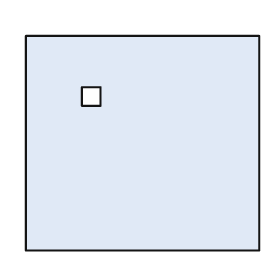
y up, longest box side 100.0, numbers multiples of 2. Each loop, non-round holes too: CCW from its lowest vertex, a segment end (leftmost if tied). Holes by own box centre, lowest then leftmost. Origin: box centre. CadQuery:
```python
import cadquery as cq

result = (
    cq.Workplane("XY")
    .moveTo(-50.0, -46.0)
    .lineTo(50.0, -46.0)
    .lineTo(50.0, 46.0)
    .lineTo(-50.0, 46.0)
    .close()
    .moveTo(-26.0, 16.0)
    .lineTo(-18.0, 16.0)
    .lineTo(-18.0, 24.0)
    .lineTo(-26.0, 24.0)
    .close()
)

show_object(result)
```